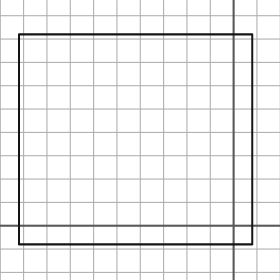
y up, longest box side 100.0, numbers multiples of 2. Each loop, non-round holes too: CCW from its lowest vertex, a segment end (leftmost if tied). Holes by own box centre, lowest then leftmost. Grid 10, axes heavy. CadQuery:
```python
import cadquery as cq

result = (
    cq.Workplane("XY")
    .moveTo(-92.0, -8.0)
    .lineTo(8.0, -8.0)
    .lineTo(8.0, 82.0)
    .lineTo(-92.0, 82.0)
    .close()
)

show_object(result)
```